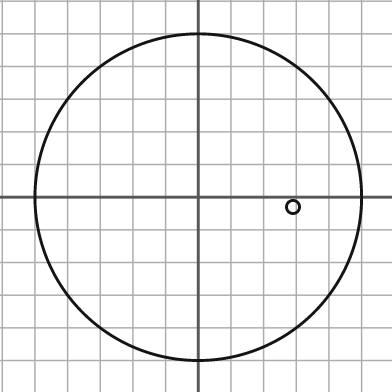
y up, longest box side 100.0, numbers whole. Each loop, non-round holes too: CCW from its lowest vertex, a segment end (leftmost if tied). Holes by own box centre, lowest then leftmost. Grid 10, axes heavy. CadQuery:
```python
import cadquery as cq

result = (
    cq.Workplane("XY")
    .moveTo(0.0, 0.0)
    .circle(50.0)
    .moveTo(29.0, -3.0)
    .circle(2.0)
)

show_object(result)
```